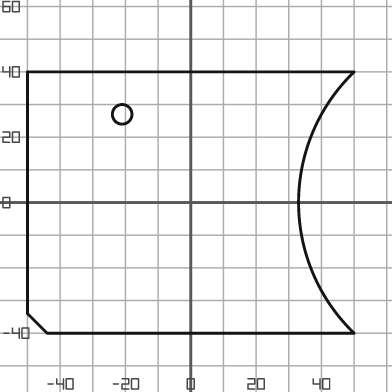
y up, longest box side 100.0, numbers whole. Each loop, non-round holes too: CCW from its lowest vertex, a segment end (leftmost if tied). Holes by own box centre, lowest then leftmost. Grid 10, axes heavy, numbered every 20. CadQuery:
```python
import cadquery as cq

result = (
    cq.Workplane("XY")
    .moveTo(-44.0, -40.0)
    .lineTo(50.0, -40.0)
    .threePointArc((33.0, 0.0), (50.0, 40.0))
    .lineTo(-50.0, 40.0)
    .lineTo(-50.0, -34.0)
    .close()
    .moveTo(-21.0, 27.0)
    .circle(3.0)
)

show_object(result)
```